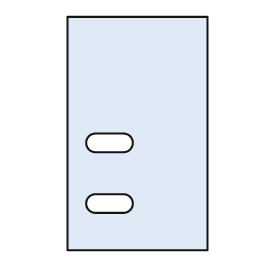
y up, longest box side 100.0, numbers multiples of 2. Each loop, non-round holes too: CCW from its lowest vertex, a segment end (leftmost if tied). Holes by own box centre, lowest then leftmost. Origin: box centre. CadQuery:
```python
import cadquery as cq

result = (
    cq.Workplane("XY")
    .moveTo(-30.0, -50.0)
    .lineTo(30.0, -50.0)
    .lineTo(30.0, 50.0)
    .lineTo(-30.0, 50.0)
    .close()
    .moveTo(-18.0, -34.0)
    .lineTo(-6.0, -34.0)
    .threePointArc((-2.0, -30.0), (-6.0, -26.0))
    .lineTo(-18.0, -26.0)
    .threePointArc((-22.0, -30.0), (-18.0, -34.0))
    .close()
    .moveTo(-18.0, -8.0)
    .lineTo(-6.0, -8.0)
    .threePointArc((-2.0, -4.0), (-6.0, 0.0))
    .lineTo(-18.0, 0.0)
    .threePointArc((-22.0, -4.0), (-18.0, -8.0))
    .close()
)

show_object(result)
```